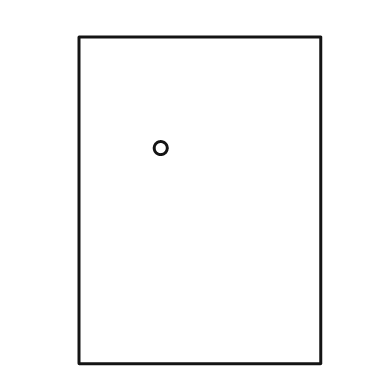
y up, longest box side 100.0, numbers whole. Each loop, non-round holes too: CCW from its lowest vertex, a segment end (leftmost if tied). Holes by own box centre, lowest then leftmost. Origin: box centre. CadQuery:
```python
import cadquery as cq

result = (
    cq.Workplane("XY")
    .moveTo(-37.0, -50.0)
    .lineTo(37.0, -50.0)
    .lineTo(37.0, 50.0)
    .lineTo(-37.0, 50.0)
    .close()
    .moveTo(-12.0, 16.0)
    .circle(2.0)
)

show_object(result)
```